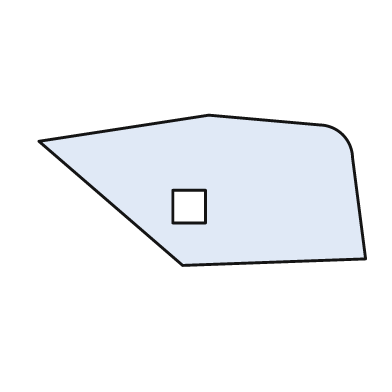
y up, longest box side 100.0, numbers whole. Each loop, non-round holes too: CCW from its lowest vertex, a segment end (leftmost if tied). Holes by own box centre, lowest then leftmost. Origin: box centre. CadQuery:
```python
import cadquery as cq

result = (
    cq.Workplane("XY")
    .moveTo(-6.0, -23.0)
    .lineTo(50.0, -21.0)
    .lineTo(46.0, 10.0)
    .threePointArc((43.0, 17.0), (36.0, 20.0))
    .lineTo(2.0, 23.0)
    .lineTo(-50.0, 15.0)
    .close()
    .moveTo(-9.0, -10.0)
    .lineTo(1.0, -10.0)
    .lineTo(1.0, 0.0)
    .lineTo(-9.0, 0.0)
    .close()
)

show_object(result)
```